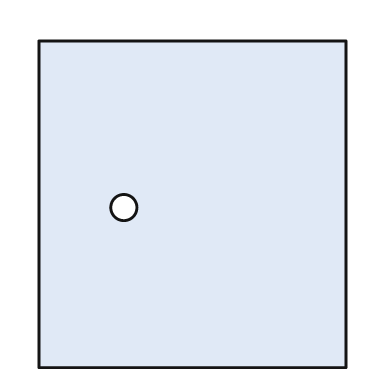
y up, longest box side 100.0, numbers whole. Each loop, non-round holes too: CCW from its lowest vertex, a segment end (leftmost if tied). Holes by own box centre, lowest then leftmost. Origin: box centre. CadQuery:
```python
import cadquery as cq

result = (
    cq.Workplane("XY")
    .moveTo(-47.0, -50.0)
    .lineTo(47.0, -50.0)
    .lineTo(47.0, 50.0)
    .lineTo(-47.0, 50.0)
    .close()
    .moveTo(-21.0, -1.0)
    .circle(4.0)
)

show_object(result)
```